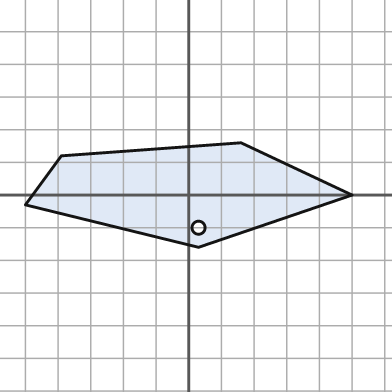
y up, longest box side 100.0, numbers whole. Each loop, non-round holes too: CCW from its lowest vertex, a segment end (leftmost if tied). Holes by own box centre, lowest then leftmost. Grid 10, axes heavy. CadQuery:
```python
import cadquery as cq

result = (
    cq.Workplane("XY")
    .moveTo(3.0, -16.0)
    .lineTo(50.0, 0.0)
    .lineTo(16.0, 16.0)
    .lineTo(-39.0, 12.0)
    .lineTo(-50.0, -3.0)
    .close()
    .moveTo(3.0, -10.0)
    .circle(2.0)
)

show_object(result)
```